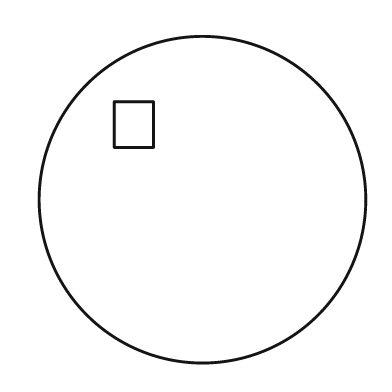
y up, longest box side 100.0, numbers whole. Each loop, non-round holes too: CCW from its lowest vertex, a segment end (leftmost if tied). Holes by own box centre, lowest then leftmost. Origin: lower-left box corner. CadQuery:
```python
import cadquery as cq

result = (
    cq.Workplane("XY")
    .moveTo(50.0, 50.0)
    .circle(50.0)
    .moveTo(23.0, 66.0)
    .lineTo(35.0, 66.0)
    .lineTo(35.0, 80.0)
    .lineTo(23.0, 80.0)
    .close()
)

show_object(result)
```